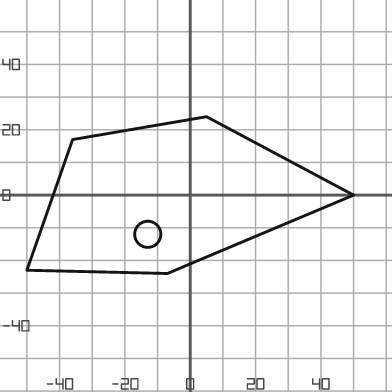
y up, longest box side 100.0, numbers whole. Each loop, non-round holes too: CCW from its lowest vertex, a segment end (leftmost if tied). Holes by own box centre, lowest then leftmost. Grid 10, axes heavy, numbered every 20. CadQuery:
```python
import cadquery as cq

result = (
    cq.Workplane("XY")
    .moveTo(-7.0, -24.0)
    .lineTo(50.0, 0.0)
    .lineTo(5.0, 24.0)
    .lineTo(-36.0, 17.0)
    .lineTo(-50.0, -23.0)
    .close()
    .moveTo(-13.0, -12.0)
    .circle(4.0)
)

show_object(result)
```